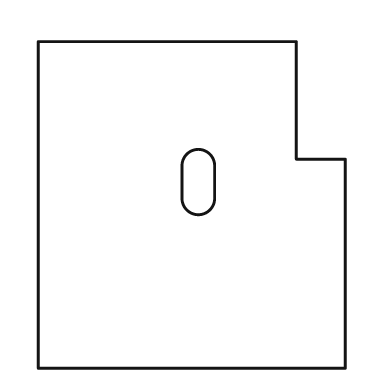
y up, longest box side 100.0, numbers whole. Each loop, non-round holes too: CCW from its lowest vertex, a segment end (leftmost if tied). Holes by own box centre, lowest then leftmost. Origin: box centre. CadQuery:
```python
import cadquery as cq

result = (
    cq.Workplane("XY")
    .moveTo(-47.0, -50.0)
    .lineTo(47.0, -50.0)
    .lineTo(47.0, 14.0)
    .lineTo(32.0, 14.0)
    .lineTo(32.0, 50.0)
    .lineTo(-47.0, 50.0)
    .close()
    .moveTo(-3.0, 2.0)
    .threePointArc((2.0, -3.0), (7.0, 2.0))
    .lineTo(7.0, 12.0)
    .threePointArc((2.0, 17.0), (-3.0, 12.0))
    .close()
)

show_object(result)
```